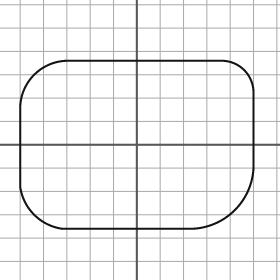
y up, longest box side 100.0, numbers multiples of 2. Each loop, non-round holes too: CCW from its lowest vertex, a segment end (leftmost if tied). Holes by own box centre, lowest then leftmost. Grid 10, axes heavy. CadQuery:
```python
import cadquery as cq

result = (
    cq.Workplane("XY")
    .moveTo(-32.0, -36.0)
    .lineTo(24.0, -36.0)
    .threePointArc((42.0, -28.0), (50.0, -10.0))
    .lineTo(50.0, 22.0)
    .threePointArc((46.0, 32.0), (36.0, 36.0))
    .lineTo(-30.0, 36.0)
    .threePointArc((-44.0, 30.0), (-50.0, 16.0))
    .lineTo(-50.0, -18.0)
    .threePointArc((-44.0, -30.0), (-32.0, -36.0))
    .close()
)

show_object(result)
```